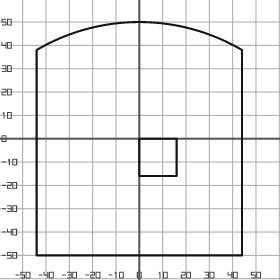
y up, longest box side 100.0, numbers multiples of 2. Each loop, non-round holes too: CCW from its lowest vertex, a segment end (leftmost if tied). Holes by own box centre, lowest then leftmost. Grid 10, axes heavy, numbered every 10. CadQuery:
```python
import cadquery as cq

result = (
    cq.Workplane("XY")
    .moveTo(-44.0, -50.0)
    .lineTo(44.0, -50.0)
    .lineTo(44.0, 38.0)
    .threePointArc((0.0, 50.0), (-44.0, 38.0))
    .close()
    .moveTo(0.0, -16.0)
    .lineTo(16.0, -16.0)
    .lineTo(16.0, 0.0)
    .lineTo(0.0, 0.0)
    .close()
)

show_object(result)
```